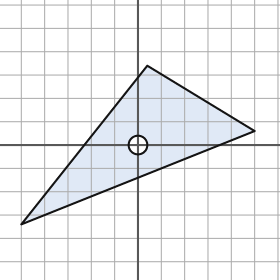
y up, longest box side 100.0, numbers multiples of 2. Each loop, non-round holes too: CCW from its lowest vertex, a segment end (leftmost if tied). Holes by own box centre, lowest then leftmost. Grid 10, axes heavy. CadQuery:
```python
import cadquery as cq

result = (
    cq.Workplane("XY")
    .moveTo(-50.0, -34.0)
    .lineTo(50.0, 6.0)
    .lineTo(4.0, 34.0)
    .close()
    .moveTo(0.0, 0.0)
    .circle(4.0)
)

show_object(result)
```